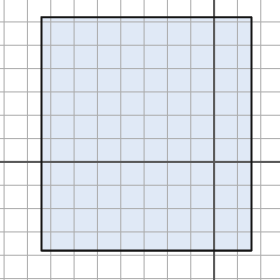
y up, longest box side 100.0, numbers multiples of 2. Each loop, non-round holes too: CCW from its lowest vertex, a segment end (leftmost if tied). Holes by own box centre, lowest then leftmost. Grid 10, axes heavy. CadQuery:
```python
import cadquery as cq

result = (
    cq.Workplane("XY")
    .moveTo(-74.0, -38.0)
    .lineTo(16.0, -38.0)
    .lineTo(16.0, 62.0)
    .lineTo(-74.0, 62.0)
    .close()
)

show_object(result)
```